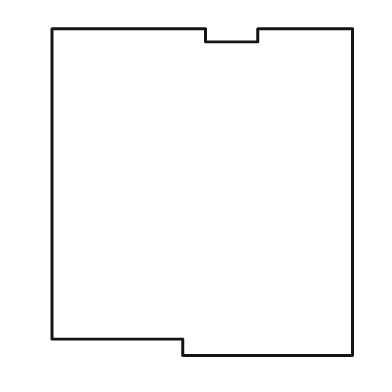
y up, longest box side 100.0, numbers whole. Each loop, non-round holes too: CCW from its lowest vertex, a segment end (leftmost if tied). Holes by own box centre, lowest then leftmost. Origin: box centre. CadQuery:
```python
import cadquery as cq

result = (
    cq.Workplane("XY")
    .moveTo(-6.0, -50.0)
    .lineTo(46.0, -50.0)
    .lineTo(46.0, 50.0)
    .lineTo(17.0, 50.0)
    .lineTo(17.0, 46.0)
    .lineTo(1.0, 46.0)
    .lineTo(1.0, 50.0)
    .lineTo(-46.0, 50.0)
    .lineTo(-46.0, -45.0)
    .lineTo(-6.0, -45.0)
    .close()
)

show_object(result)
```